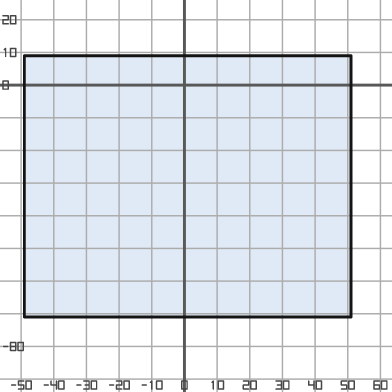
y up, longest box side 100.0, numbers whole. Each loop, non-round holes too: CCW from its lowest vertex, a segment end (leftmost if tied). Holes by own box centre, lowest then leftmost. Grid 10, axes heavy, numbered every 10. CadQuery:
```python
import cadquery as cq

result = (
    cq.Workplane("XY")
    .moveTo(-49.0, -71.0)
    .lineTo(51.0, -71.0)
    .lineTo(51.0, 9.0)
    .lineTo(-49.0, 9.0)
    .close()
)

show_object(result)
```